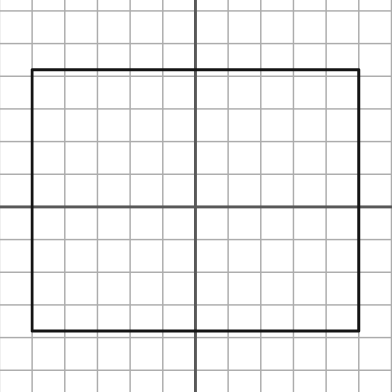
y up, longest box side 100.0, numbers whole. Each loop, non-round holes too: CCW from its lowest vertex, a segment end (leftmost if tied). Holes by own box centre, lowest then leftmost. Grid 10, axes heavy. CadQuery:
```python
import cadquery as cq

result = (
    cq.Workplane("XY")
    .moveTo(-50.0, -38.0)
    .lineTo(50.0, -38.0)
    .lineTo(50.0, 42.0)
    .lineTo(-50.0, 42.0)
    .close()
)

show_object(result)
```